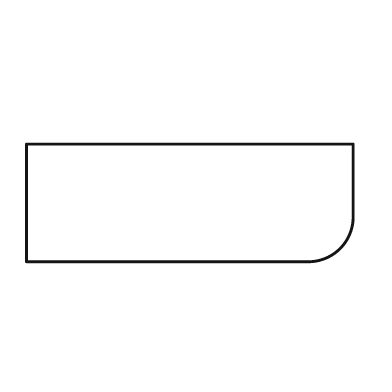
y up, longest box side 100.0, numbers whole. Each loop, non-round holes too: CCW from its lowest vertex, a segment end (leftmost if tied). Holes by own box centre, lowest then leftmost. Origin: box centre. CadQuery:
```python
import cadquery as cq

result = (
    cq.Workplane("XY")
    .moveTo(-50.0, -18.0)
    .lineTo(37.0, -18.0)
    .threePointArc((46.0, -14.0), (50.0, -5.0))
    .lineTo(50.0, 18.0)
    .lineTo(-50.0, 18.0)
    .close()
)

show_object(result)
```